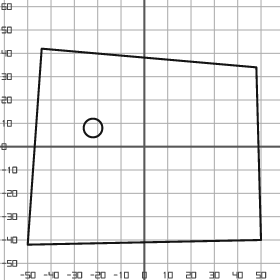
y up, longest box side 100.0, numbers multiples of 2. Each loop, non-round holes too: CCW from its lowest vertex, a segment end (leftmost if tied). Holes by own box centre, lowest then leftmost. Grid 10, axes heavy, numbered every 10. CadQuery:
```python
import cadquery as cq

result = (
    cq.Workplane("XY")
    .moveTo(-50.0, -42.0)
    .lineTo(50.0, -40.0)
    .lineTo(48.0, 34.0)
    .lineTo(-44.0, 42.0)
    .close()
    .moveTo(-22.0, 8.0)
    .circle(4.0)
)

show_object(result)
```